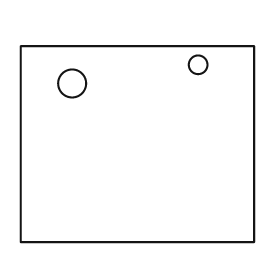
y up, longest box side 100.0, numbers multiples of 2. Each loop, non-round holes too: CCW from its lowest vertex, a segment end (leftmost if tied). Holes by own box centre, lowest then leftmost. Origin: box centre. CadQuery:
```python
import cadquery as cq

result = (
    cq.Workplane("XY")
    .moveTo(-50.0, -42.0)
    .lineTo(50.0, -42.0)
    .lineTo(50.0, 42.0)
    .lineTo(-50.0, 42.0)
    .close()
    .moveTo(-28.0, 26.0)
    .circle(6.0)
    .moveTo(26.0, 34.0)
    .circle(4.0)
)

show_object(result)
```